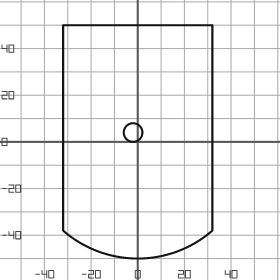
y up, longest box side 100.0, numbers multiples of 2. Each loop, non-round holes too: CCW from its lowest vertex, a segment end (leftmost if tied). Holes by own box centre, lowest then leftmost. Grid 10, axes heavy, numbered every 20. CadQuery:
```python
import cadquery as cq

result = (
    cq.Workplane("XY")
    .moveTo(-32.0, -38.0)
    .threePointArc((0.0, -50.0), (32.0, -38.0))
    .lineTo(32.0, 50.0)
    .lineTo(-32.0, 50.0)
    .close()
    .moveTo(-2.0, 4.0)
    .circle(4.0)
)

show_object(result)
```